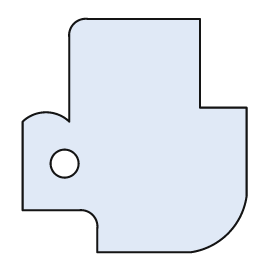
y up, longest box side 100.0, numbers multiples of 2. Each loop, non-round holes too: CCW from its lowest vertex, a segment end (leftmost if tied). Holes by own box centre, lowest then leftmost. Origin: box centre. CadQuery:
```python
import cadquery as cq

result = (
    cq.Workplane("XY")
    .moveTo(-16.0, -50.0)
    .lineTo(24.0, -50.0)
    .threePointArc((40.0, -42.0), (48.0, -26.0))
    .lineTo(48.0, 12.0)
    .lineTo(28.0, 12.0)
    .lineTo(28.0, 50.0)
    .lineTo(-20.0, 50.0)
    .threePointArc((-26.0, 48.0), (-28.0, 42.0))
    .lineTo(-28.0, 6.0)
    .threePointArc((-38.0, 10.0), (-48.0, 6.0))
    .lineTo(-48.0, -32.0)
    .lineTo(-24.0, -32.0)
    .threePointArc((-18.0, -34.0), (-16.0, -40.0))
    .close()
    .moveTo(-30.0, -12.0)
    .circle(6.0)
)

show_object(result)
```